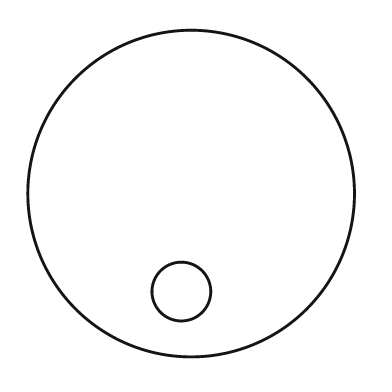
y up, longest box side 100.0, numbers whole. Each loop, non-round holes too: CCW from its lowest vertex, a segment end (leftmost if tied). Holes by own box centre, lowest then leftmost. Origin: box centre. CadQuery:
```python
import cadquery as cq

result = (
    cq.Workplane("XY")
    .moveTo(0.0, 0.0)
    .circle(50.0)
    .moveTo(-3.0, -30.0)
    .circle(9.0)
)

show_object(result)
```